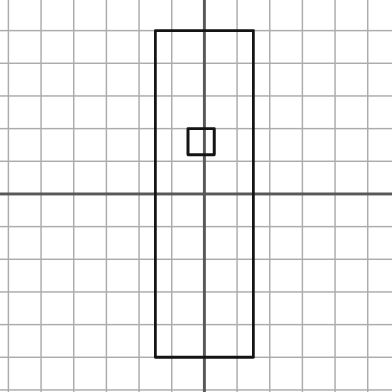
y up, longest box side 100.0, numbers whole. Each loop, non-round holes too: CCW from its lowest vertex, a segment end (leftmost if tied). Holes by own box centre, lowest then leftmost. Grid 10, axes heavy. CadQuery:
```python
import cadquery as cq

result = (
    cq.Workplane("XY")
    .moveTo(-15.0, -50.0)
    .lineTo(15.0, -50.0)
    .lineTo(15.0, 50.0)
    .lineTo(-15.0, 50.0)
    .close()
    .moveTo(-5.0, 12.0)
    .lineTo(3.0, 12.0)
    .lineTo(3.0, 20.0)
    .lineTo(-5.0, 20.0)
    .close()
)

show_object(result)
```